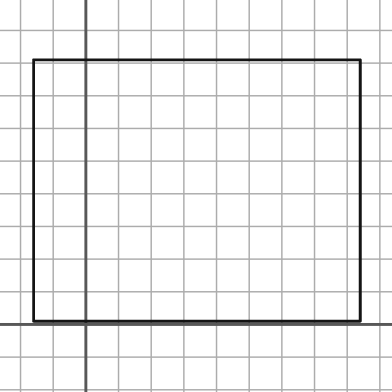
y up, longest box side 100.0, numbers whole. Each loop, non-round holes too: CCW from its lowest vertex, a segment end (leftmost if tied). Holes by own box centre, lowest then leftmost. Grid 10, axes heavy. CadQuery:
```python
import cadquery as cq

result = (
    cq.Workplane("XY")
    .moveTo(-16.0, 1.0)
    .lineTo(84.0, 1.0)
    .lineTo(84.0, 81.0)
    .lineTo(-16.0, 81.0)
    .close()
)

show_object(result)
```